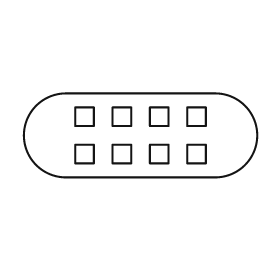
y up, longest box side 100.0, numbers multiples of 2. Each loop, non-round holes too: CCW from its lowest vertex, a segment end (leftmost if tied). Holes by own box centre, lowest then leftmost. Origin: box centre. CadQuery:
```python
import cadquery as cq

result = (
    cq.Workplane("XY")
    .moveTo(-32.0, -18.0)
    .lineTo(32.0, -18.0)
    .threePointArc((50.0, 0.0), (32.0, 18.0))
    .lineTo(-32.0, 18.0)
    .threePointArc((-50.0, 0.0), (-32.0, -18.0))
    .close()
    .moveTo(-28.0, -12.0)
    .lineTo(-20.0, -12.0)
    .lineTo(-20.0, -4.0)
    .lineTo(-28.0, -4.0)
    .close()
    .moveTo(-12.0, -12.0)
    .lineTo(-4.0, -12.0)
    .lineTo(-4.0, -4.0)
    .lineTo(-12.0, -4.0)
    .close()
    .moveTo(4.0, -12.0)
    .lineTo(12.0, -12.0)
    .lineTo(12.0, -4.0)
    .lineTo(4.0, -4.0)
    .close()
    .moveTo(20.0, -12.0)
    .lineTo(28.0, -12.0)
    .lineTo(28.0, -4.0)
    .lineTo(20.0, -4.0)
    .close()
    .moveTo(-28.0, 4.0)
    .lineTo(-20.0, 4.0)
    .lineTo(-20.0, 12.0)
    .lineTo(-28.0, 12.0)
    .close()
    .moveTo(-12.0, 4.0)
    .lineTo(-4.0, 4.0)
    .lineTo(-4.0, 12.0)
    .lineTo(-12.0, 12.0)
    .close()
    .moveTo(4.0, 4.0)
    .lineTo(12.0, 4.0)
    .lineTo(12.0, 12.0)
    .lineTo(4.0, 12.0)
    .close()
    .moveTo(20.0, 4.0)
    .lineTo(28.0, 4.0)
    .lineTo(28.0, 12.0)
    .lineTo(20.0, 12.0)
    .close()
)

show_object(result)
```